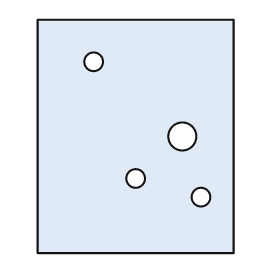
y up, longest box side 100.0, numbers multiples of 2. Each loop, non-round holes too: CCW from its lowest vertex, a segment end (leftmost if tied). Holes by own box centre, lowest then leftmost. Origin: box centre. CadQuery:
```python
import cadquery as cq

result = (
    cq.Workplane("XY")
    .moveTo(-42.0, -50.0)
    .lineTo(42.0, -50.0)
    .lineTo(42.0, 50.0)
    .lineTo(-42.0, 50.0)
    .close()
    .moveTo(28.0, -26.0)
    .circle(4.0)
    .moveTo(0.0, -18.0)
    .circle(4.0)
    .moveTo(20.0, 0.0)
    .circle(6.0)
    .moveTo(-18.0, 32.0)
    .circle(4.0)
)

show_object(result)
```